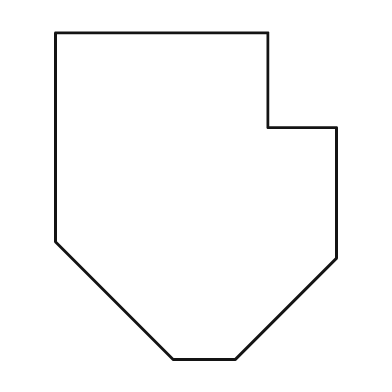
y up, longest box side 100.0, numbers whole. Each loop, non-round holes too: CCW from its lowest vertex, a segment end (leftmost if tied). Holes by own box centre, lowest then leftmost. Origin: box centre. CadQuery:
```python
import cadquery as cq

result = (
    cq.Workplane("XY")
    .moveTo(-7.0, -50.0)
    .lineTo(12.0, -50.0)
    .lineTo(43.0, -19.0)
    .lineTo(43.0, 21.0)
    .lineTo(22.0, 21.0)
    .lineTo(22.0, 50.0)
    .lineTo(-43.0, 50.0)
    .lineTo(-43.0, -14.0)
    .close()
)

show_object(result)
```